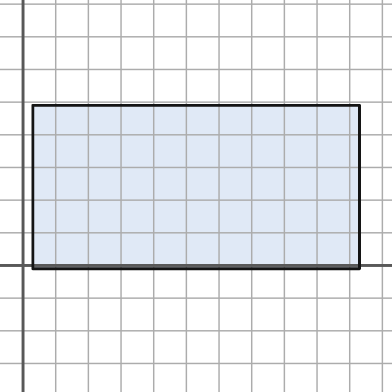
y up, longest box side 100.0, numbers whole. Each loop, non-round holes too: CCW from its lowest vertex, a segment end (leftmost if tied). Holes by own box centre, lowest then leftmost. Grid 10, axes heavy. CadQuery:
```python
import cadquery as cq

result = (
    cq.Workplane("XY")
    .moveTo(3.0, -1.0)
    .lineTo(103.0, -1.0)
    .lineTo(103.0, 49.0)
    .lineTo(3.0, 49.0)
    .close()
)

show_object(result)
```